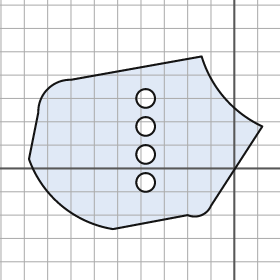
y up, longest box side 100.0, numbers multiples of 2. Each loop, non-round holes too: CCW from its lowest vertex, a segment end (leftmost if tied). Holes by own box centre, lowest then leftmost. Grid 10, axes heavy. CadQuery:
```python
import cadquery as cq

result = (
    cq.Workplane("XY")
    .moveTo(-52.0, -26.0)
    .lineTo(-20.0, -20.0)
    .threePointArc((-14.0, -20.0), (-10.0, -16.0))
    .lineTo(12.0, 18.0)
    .threePointArc((-4.0, 30.0), (-14.0, 48.0))
    .lineTo(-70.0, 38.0)
    .threePointArc((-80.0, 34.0), (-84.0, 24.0))
    .lineTo(-88.0, 4.0)
    .threePointArc((-74.0, -16.0), (-52.0, -26.0))
    .close()
    .moveTo(-38.0, -6.0)
    .circle(4.0)
    .moveTo(-38.0, 6.0)
    .circle(4.0)
    .moveTo(-38.0, 18.0)
    .circle(4.0)
    .moveTo(-38.0, 30.0)
    .circle(4.0)
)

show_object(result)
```